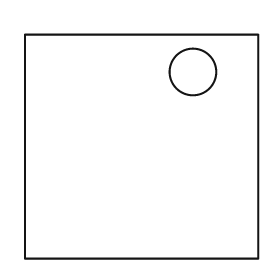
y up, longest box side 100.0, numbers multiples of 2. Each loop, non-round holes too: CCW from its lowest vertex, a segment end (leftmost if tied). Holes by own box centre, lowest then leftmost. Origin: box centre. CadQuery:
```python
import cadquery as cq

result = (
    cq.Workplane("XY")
    .moveTo(-50.0, -48.0)
    .lineTo(50.0, -48.0)
    .lineTo(50.0, 48.0)
    .lineTo(-50.0, 48.0)
    .close()
    .moveTo(22.0, 32.0)
    .circle(10.0)
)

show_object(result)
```